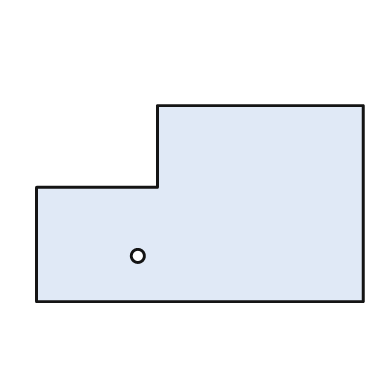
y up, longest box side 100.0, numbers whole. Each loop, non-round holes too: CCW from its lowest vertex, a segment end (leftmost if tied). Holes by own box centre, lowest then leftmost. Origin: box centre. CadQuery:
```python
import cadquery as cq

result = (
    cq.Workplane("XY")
    .moveTo(-50.0, -30.0)
    .lineTo(50.0, -30.0)
    .lineTo(50.0, 30.0)
    .lineTo(-13.0, 30.0)
    .lineTo(-13.0, 5.0)
    .lineTo(-50.0, 5.0)
    .close()
    .moveTo(-19.0, -16.0)
    .circle(2.0)
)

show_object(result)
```